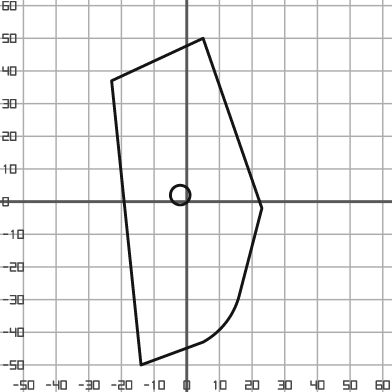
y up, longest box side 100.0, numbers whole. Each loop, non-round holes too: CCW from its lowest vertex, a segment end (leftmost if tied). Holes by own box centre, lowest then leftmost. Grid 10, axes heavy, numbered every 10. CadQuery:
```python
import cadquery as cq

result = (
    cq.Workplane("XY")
    .moveTo(-14.0, -50.0)
    .lineTo(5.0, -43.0)
    .threePointArc((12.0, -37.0), (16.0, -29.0))
    .lineTo(23.0, -2.0)
    .lineTo(5.0, 50.0)
    .lineTo(-23.0, 37.0)
    .close()
    .moveTo(-2.0, 2.0)
    .circle(3.0)
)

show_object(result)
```